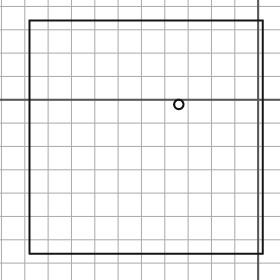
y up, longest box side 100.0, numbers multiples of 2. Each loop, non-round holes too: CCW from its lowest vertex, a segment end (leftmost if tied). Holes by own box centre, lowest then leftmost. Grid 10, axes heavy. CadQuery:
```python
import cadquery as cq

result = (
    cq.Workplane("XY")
    .moveTo(-98.0, -66.0)
    .lineTo(2.0, -66.0)
    .lineTo(2.0, 34.0)
    .lineTo(-98.0, 34.0)
    .close()
    .moveTo(-34.0, -2.0)
    .circle(2.0)
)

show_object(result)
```